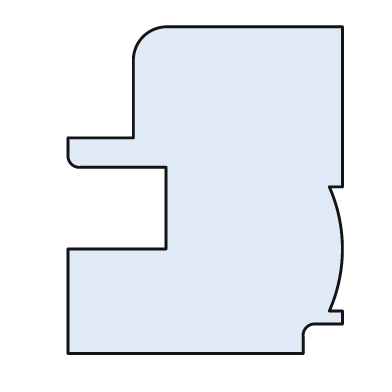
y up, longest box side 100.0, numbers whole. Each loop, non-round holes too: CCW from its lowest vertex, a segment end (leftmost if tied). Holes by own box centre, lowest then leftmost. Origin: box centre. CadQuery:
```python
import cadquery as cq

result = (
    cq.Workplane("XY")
    .moveTo(-42.0, -50.0)
    .lineTo(30.0, -50.0)
    .lineTo(30.0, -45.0)
    .threePointArc((31.0, -42.0), (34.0, -41.0))
    .lineTo(42.0, -41.0)
    .lineTo(42.0, -37.0)
    .lineTo(38.0, -37.0)
    .threePointArc((42.0, -18.0), (38.0, 1.0))
    .lineTo(42.0, 1.0)
    .lineTo(42.0, 50.0)
    .lineTo(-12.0, 50.0)
    .threePointArc((-19.0, 47.0), (-22.0, 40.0))
    .lineTo(-22.0, 16.0)
    .lineTo(-42.0, 16.0)
    .lineTo(-42.0, 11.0)
    .threePointArc((-41.0, 8.0), (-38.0, 7.0))
    .lineTo(-12.0, 7.0)
    .lineTo(-12.0, -18.0)
    .lineTo(-42.0, -18.0)
    .close()
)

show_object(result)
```